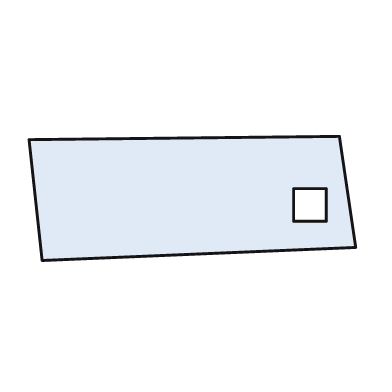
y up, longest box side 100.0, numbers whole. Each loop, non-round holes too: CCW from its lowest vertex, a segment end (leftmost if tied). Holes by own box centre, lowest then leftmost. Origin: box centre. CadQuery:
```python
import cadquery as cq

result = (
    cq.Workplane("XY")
    .moveTo(-46.0, -19.0)
    .lineTo(50.0, -15.0)
    .lineTo(45.0, 19.0)
    .lineTo(-50.0, 18.0)
    .close()
    .moveTo(31.0, -7.0)
    .lineTo(41.0, -7.0)
    .lineTo(41.0, 3.0)
    .lineTo(31.0, 3.0)
    .close()
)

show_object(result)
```